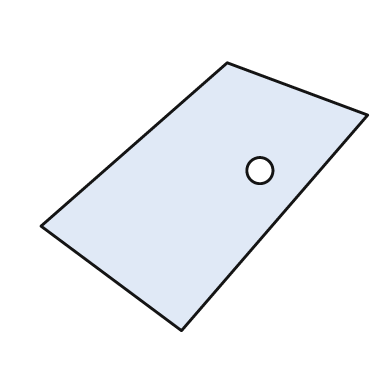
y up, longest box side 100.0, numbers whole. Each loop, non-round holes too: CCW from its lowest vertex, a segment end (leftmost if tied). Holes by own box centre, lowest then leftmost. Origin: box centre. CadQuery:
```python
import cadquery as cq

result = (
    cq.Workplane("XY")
    .moveTo(-7.0, -41.0)
    .lineTo(50.0, 25.0)
    .lineTo(7.0, 41.0)
    .lineTo(-50.0, -9.0)
    .close()
    .moveTo(17.0, 8.0)
    .circle(4.0)
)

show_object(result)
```